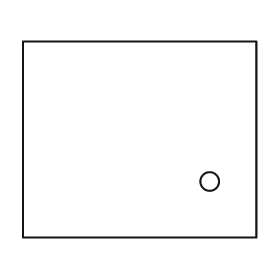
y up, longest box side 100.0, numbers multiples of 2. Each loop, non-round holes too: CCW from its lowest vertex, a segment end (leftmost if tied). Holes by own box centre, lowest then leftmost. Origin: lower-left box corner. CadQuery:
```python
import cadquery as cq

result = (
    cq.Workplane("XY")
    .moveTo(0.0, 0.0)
    .lineTo(100.0, 0.0)
    .lineTo(100.0, 84.0)
    .lineTo(0.0, 84.0)
    .close()
    .moveTo(80.0, 24.0)
    .circle(4.0)
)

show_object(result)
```